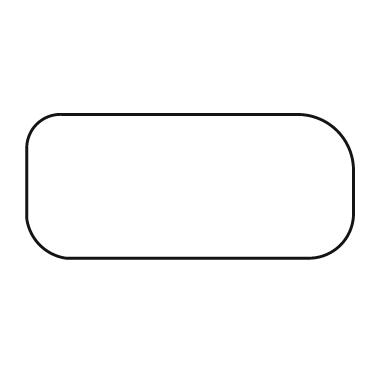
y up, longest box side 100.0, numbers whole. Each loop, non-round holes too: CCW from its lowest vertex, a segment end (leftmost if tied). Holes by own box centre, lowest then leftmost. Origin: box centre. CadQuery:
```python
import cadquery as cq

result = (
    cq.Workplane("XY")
    .moveTo(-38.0, -22.0)
    .lineTo(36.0, -22.0)
    .threePointArc((46.0, -18.0), (50.0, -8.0))
    .lineTo(50.0, 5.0)
    .threePointArc((45.0, 17.0), (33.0, 22.0))
    .lineTo(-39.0, 22.0)
    .threePointArc((-47.0, 19.0), (-50.0, 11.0))
    .lineTo(-50.0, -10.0)
    .threePointArc((-46.0, -18.0), (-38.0, -22.0))
    .close()
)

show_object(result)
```